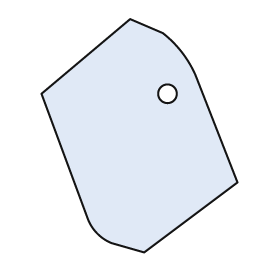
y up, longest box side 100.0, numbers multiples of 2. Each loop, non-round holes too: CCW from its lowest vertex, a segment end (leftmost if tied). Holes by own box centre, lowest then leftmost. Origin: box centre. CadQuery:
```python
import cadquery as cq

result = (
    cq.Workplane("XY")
    .moveTo(2.0, -50.0)
    .lineTo(42.0, -20.0)
    .lineTo(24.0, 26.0)
    .threePointArc((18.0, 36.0), (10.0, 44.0))
    .lineTo(-4.0, 50.0)
    .lineTo(-42.0, 18.0)
    .lineTo(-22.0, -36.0)
    .threePointArc((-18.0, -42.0), (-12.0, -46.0))
    .close()
    .moveTo(12.0, 18.0)
    .circle(4.0)
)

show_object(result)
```